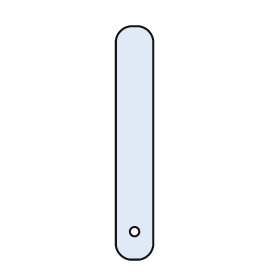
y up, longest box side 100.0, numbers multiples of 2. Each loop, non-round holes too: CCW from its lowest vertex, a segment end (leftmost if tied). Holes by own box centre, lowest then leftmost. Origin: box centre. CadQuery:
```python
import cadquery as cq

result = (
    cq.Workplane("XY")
    .moveTo(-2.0, -50.0)
    .lineTo(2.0, -50.0)
    .threePointArc((6.0, -48.0), (8.0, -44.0))
    .lineTo(8.0, 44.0)
    .threePointArc((6.0, 48.0), (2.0, 50.0))
    .lineTo(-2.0, 50.0)
    .threePointArc((-6.0, 48.0), (-8.0, 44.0))
    .lineTo(-8.0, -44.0)
    .threePointArc((-6.0, -48.0), (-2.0, -50.0))
    .close()
    .moveTo(0.0, -38.0)
    .circle(2.0)
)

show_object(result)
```